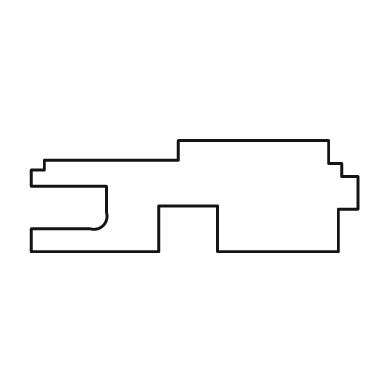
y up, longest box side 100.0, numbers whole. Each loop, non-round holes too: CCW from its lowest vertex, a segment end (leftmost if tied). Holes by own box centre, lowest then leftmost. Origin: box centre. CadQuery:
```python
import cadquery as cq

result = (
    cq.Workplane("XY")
    .moveTo(-50.0, -17.0)
    .lineTo(-11.0, -17.0)
    .lineTo(-11.0, -3.0)
    .lineTo(7.0, -3.0)
    .lineTo(7.0, -17.0)
    .lineTo(44.0, -17.0)
    .lineTo(44.0, -4.0)
    .lineTo(50.0, -4.0)
    .lineTo(50.0, 6.0)
    .lineTo(45.0, 6.0)
    .lineTo(45.0, 10.0)
    .lineTo(41.0, 10.0)
    .lineTo(41.0, 17.0)
    .lineTo(-5.0, 17.0)
    .lineTo(-5.0, 11.0)
    .lineTo(-46.0, 11.0)
    .lineTo(-46.0, 8.0)
    .lineTo(-50.0, 8.0)
    .lineTo(-50.0, 3.0)
    .lineTo(-27.0, 3.0)
    .lineTo(-27.0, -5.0)
    .threePointArc((-28.0, -9.0), (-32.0, -10.0))
    .lineTo(-50.0, -10.0)
    .close()
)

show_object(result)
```